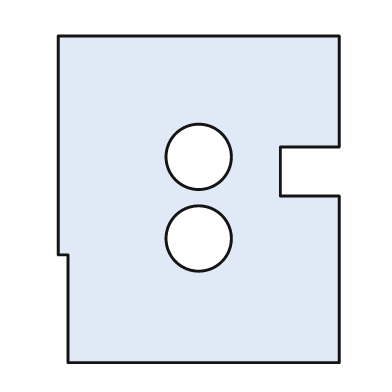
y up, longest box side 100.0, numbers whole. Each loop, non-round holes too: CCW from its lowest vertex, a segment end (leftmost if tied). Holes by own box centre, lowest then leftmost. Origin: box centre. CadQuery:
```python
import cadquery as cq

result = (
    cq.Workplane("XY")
    .moveTo(-40.0, -50.0)
    .lineTo(43.0, -50.0)
    .lineTo(43.0, 1.0)
    .lineTo(25.0, 1.0)
    .lineTo(25.0, 16.0)
    .lineTo(43.0, 16.0)
    .lineTo(43.0, 50.0)
    .lineTo(-43.0, 50.0)
    .lineTo(-43.0, -17.0)
    .lineTo(-40.0, -17.0)
    .close()
    .moveTo(0.0, -12.0)
    .circle(10.0)
    .moveTo(0.0, 13.0)
    .circle(10.0)
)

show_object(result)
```